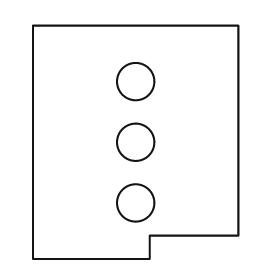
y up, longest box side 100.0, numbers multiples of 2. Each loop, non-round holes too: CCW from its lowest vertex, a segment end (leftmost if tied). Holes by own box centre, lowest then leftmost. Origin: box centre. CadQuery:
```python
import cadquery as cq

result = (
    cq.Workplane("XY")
    .moveTo(-44.0, -50.0)
    .lineTo(6.0, -50.0)
    .lineTo(6.0, -40.0)
    .lineTo(44.0, -40.0)
    .lineTo(44.0, 50.0)
    .lineTo(-44.0, 50.0)
    .close()
    .moveTo(0.0, -26.0)
    .circle(8.0)
    .moveTo(0.0, 0.0)
    .circle(8.0)
    .moveTo(0.0, 26.0)
    .circle(8.0)
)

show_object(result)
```